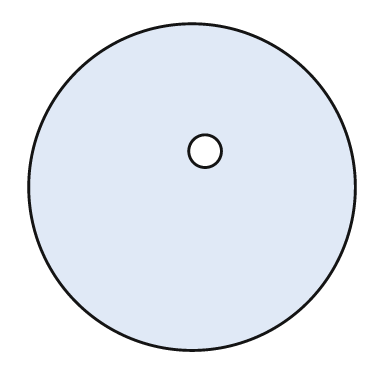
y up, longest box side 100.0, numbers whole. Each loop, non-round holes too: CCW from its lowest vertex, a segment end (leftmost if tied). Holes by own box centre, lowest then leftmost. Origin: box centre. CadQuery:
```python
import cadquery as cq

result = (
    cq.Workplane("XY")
    .moveTo(0.0, 0.0)
    .circle(50.0)
    .moveTo(4.0, 11.0)
    .circle(5.0)
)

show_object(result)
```